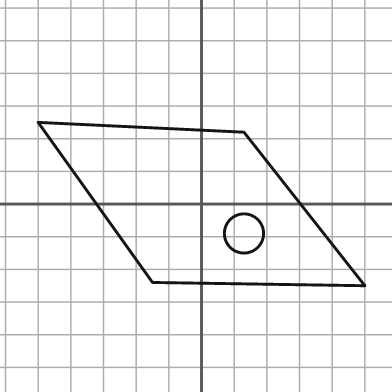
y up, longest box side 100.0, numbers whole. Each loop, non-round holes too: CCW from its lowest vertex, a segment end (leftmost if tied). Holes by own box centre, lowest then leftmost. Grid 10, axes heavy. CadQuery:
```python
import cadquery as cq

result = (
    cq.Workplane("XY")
    .moveTo(50.0, -25.0)
    .lineTo(13.0, 22.0)
    .lineTo(-50.0, 25.0)
    .lineTo(-15.0, -24.0)
    .close()
    .moveTo(13.0, -9.0)
    .circle(6.0)
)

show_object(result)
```